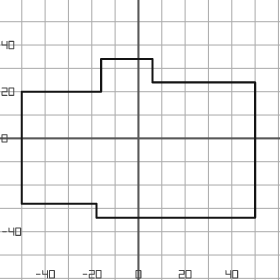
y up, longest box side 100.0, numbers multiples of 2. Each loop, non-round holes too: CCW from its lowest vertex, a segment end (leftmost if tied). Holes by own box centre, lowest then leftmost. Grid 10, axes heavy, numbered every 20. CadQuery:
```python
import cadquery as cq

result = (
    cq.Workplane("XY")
    .moveTo(-18.0, -34.0)
    .lineTo(50.0, -34.0)
    .lineTo(50.0, 24.0)
    .lineTo(6.0, 24.0)
    .lineTo(6.0, 34.0)
    .lineTo(-16.0, 34.0)
    .lineTo(-16.0, 20.0)
    .lineTo(-50.0, 20.0)
    .lineTo(-50.0, -28.0)
    .lineTo(-18.0, -28.0)
    .close()
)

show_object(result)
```